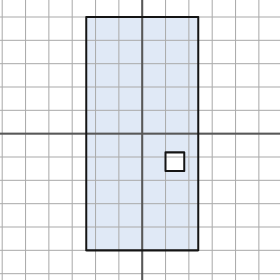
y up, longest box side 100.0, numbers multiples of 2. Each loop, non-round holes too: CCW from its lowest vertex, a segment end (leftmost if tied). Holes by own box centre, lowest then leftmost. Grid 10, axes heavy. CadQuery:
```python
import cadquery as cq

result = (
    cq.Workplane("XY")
    .moveTo(-24.0, -50.0)
    .lineTo(24.0, -50.0)
    .lineTo(24.0, 50.0)
    .lineTo(-24.0, 50.0)
    .close()
    .moveTo(10.0, -16.0)
    .lineTo(18.0, -16.0)
    .lineTo(18.0, -8.0)
    .lineTo(10.0, -8.0)
    .close()
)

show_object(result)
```